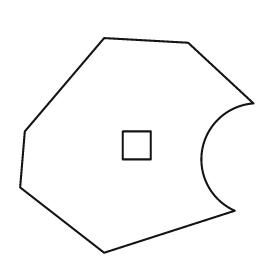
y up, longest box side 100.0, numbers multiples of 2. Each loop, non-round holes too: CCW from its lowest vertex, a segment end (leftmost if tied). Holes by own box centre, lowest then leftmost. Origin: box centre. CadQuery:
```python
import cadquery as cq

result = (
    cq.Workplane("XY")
    .moveTo(-14.0, -46.0)
    .lineTo(42.0, -28.0)
    .threePointArc((28.0, -2.0), (50.0, 18.0))
    .lineTo(22.0, 44.0)
    .lineTo(-14.0, 46.0)
    .lineTo(-48.0, 6.0)
    .lineTo(-50.0, -18.0)
    .close()
    .moveTo(-6.0, -6.0)
    .lineTo(6.0, -6.0)
    .lineTo(6.0, 6.0)
    .lineTo(-6.0, 6.0)
    .close()
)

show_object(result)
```